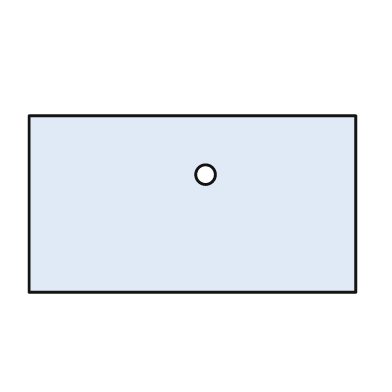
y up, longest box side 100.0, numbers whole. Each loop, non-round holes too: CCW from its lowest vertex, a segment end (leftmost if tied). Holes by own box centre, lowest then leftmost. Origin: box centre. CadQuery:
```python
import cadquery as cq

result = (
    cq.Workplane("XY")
    .moveTo(-50.0, -27.0)
    .lineTo(50.0, -27.0)
    .lineTo(50.0, 27.0)
    .lineTo(-50.0, 27.0)
    .close()
    .moveTo(4.0, 9.0)
    .circle(3.0)
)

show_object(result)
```